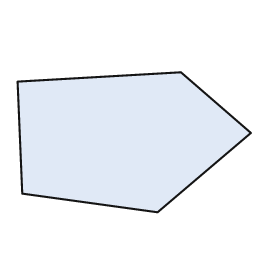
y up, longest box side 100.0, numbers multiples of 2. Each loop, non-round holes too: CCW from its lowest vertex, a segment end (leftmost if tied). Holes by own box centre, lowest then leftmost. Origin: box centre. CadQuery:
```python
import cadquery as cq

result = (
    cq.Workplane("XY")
    .moveTo(10.0, -30.0)
    .lineTo(50.0, 4.0)
    .lineTo(20.0, 30.0)
    .lineTo(-50.0, 26.0)
    .lineTo(-48.0, -22.0)
    .close()
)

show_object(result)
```